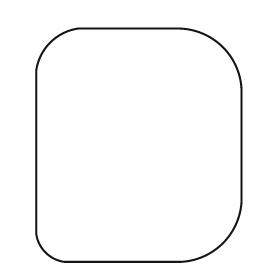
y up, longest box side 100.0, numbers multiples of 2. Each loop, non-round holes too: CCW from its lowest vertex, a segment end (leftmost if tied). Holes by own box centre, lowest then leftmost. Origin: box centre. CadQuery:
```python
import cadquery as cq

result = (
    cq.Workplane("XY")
    .moveTo(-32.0, -50.0)
    .lineTo(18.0, -50.0)
    .threePointArc((36.0, -42.0), (44.0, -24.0))
    .lineTo(44.0, 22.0)
    .threePointArc((36.0, 42.0), (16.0, 50.0))
    .lineTo(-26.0, 50.0)
    .threePointArc((-38.0, 44.0), (-44.0, 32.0))
    .lineTo(-44.0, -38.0)
    .threePointArc((-40.0, -46.0), (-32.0, -50.0))
    .close()
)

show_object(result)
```